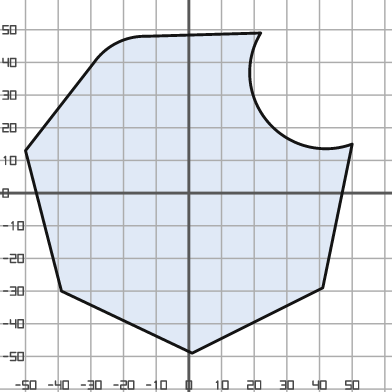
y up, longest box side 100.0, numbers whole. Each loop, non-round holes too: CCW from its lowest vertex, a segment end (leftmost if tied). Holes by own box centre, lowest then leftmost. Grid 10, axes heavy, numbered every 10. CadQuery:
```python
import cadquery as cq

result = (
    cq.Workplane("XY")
    .moveTo(1.0, -49.0)
    .lineTo(41.0, -29.0)
    .lineTo(50.0, 15.0)
    .threePointArc((24.0, 22.0), (22.0, 49.0))
    .lineTo(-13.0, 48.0)
    .threePointArc((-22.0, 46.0), (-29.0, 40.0))
    .lineTo(-50.0, 13.0)
    .lineTo(-39.0, -30.0)
    .close()
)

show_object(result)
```